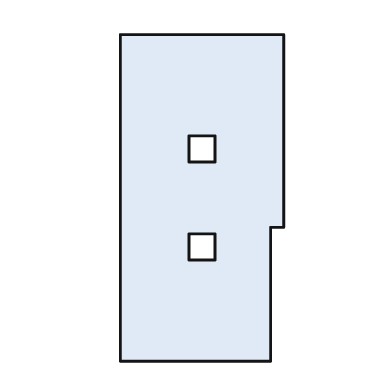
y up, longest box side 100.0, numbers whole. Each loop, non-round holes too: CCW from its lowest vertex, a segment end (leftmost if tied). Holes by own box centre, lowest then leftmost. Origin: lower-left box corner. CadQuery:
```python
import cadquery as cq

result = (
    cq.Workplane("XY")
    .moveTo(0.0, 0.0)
    .lineTo(46.0, 0.0)
    .lineTo(46.0, 41.0)
    .lineTo(50.0, 41.0)
    .lineTo(50.0, 100.0)
    .lineTo(0.0, 100.0)
    .close()
    .moveTo(21.0, 31.0)
    .lineTo(29.0, 31.0)
    .lineTo(29.0, 39.0)
    .lineTo(21.0, 39.0)
    .close()
    .moveTo(21.0, 61.0)
    .lineTo(29.0, 61.0)
    .lineTo(29.0, 69.0)
    .lineTo(21.0, 69.0)
    .close()
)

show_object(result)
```